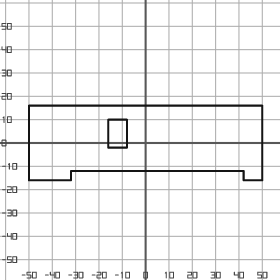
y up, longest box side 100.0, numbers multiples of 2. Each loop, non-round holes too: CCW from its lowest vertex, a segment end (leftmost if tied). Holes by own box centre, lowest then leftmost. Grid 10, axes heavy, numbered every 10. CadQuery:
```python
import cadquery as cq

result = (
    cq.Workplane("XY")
    .moveTo(-50.0, -16.0)
    .lineTo(-32.0, -16.0)
    .lineTo(-32.0, -12.0)
    .lineTo(42.0, -12.0)
    .lineTo(42.0, -16.0)
    .lineTo(50.0, -16.0)
    .lineTo(50.0, 16.0)
    .lineTo(-50.0, 16.0)
    .close()
    .moveTo(-16.0, -2.0)
    .lineTo(-8.0, -2.0)
    .lineTo(-8.0, 10.0)
    .lineTo(-16.0, 10.0)
    .close()
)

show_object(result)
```